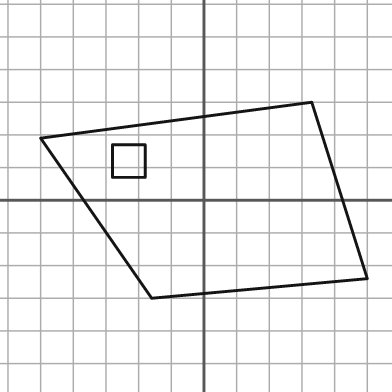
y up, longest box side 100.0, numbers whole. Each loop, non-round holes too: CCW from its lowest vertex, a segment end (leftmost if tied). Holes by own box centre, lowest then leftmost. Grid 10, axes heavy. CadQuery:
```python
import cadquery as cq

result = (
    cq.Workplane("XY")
    .moveTo(-16.0, -30.0)
    .lineTo(50.0, -24.0)
    .lineTo(33.0, 30.0)
    .lineTo(-50.0, 19.0)
    .close()
    .moveTo(-28.0, 7.0)
    .lineTo(-18.0, 7.0)
    .lineTo(-18.0, 17.0)
    .lineTo(-28.0, 17.0)
    .close()
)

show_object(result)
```